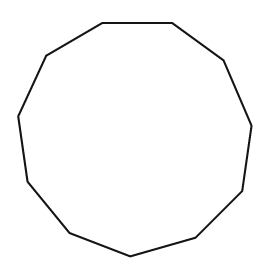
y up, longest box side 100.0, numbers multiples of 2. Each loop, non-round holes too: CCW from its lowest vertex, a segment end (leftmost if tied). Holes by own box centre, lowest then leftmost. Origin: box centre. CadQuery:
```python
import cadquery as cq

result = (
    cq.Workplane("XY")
    .moveTo(-2.0, -50.0)
    .lineTo(26.0, -42.0)
    .lineTo(46.0, -22.0)
    .lineTo(50.0, 6.0)
    .lineTo(38.0, 34.0)
    .lineTo(16.0, 50.0)
    .lineTo(-14.0, 50.0)
    .lineTo(-38.0, 36.0)
    .lineTo(-50.0, 10.0)
    .lineTo(-46.0, -18.0)
    .lineTo(-28.0, -40.0)
    .close()
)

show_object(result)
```